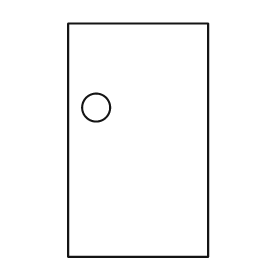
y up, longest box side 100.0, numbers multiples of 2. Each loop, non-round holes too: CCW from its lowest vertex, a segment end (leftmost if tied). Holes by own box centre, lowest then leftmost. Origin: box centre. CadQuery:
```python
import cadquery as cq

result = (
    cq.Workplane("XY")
    .moveTo(-30.0, -50.0)
    .lineTo(30.0, -50.0)
    .lineTo(30.0, 50.0)
    .lineTo(-30.0, 50.0)
    .close()
    .moveTo(-18.0, 14.0)
    .circle(6.0)
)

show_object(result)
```